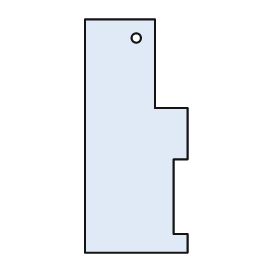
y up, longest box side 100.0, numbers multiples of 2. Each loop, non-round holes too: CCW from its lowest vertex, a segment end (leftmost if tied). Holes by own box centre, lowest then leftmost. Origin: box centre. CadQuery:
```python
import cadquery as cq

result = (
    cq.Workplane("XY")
    .moveTo(-22.0, -50.0)
    .lineTo(22.0, -50.0)
    .lineTo(22.0, -42.0)
    .lineTo(16.0, -42.0)
    .lineTo(16.0, -10.0)
    .lineTo(22.0, -10.0)
    .lineTo(22.0, 12.0)
    .lineTo(8.0, 12.0)
    .lineTo(8.0, 50.0)
    .lineTo(-22.0, 50.0)
    .close()
    .moveTo(0.0, 42.0)
    .circle(2.0)
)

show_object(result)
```